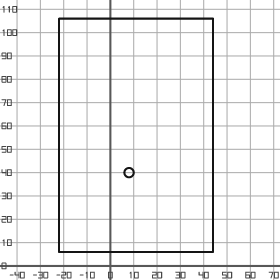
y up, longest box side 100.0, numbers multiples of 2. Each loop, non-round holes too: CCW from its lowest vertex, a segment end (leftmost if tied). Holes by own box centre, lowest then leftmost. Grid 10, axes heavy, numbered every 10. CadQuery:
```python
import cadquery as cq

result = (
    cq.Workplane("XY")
    .moveTo(-22.0, 6.0)
    .lineTo(44.0, 6.0)
    .lineTo(44.0, 106.0)
    .lineTo(-22.0, 106.0)
    .close()
    .moveTo(8.0, 40.0)
    .circle(2.0)
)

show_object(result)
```